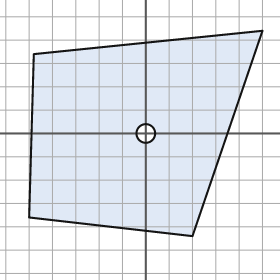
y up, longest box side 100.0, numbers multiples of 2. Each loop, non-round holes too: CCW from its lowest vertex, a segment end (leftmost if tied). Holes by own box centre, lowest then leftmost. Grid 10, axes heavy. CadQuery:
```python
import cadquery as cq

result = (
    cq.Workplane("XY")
    .moveTo(20.0, -44.0)
    .lineTo(50.0, 44.0)
    .lineTo(-48.0, 34.0)
    .lineTo(-50.0, -36.0)
    .close()
    .moveTo(0.0, 0.0)
    .circle(4.0)
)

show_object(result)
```